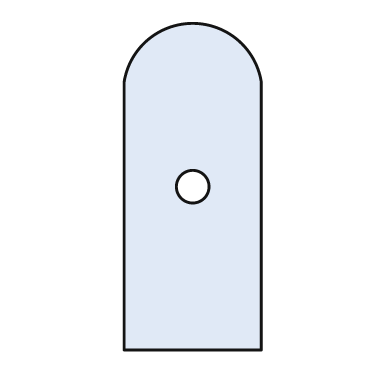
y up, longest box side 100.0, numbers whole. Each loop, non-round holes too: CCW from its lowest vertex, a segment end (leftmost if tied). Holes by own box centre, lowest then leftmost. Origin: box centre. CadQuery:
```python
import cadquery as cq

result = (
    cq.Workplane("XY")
    .moveTo(-21.0, -50.0)
    .lineTo(21.0, -50.0)
    .lineTo(21.0, 32.0)
    .threePointArc((0.0, 50.0), (-21.0, 32.0))
    .close()
    .moveTo(0.0, 0.0)
    .circle(5.0)
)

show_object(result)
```